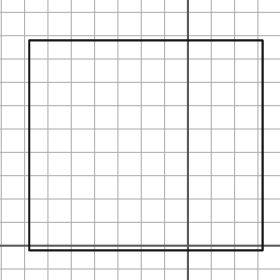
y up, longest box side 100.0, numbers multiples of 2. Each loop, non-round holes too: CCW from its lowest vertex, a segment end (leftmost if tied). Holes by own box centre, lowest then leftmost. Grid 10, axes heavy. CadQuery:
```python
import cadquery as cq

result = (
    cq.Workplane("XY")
    .moveTo(-68.0, -2.0)
    .lineTo(32.0, -2.0)
    .lineTo(32.0, 88.0)
    .lineTo(-68.0, 88.0)
    .close()
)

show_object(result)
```